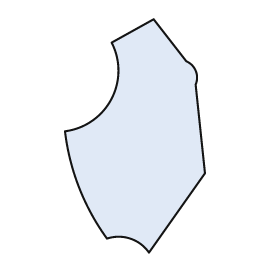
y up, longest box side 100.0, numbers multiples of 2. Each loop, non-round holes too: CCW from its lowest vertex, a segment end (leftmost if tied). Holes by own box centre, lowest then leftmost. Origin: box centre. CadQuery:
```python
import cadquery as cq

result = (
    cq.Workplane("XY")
    .moveTo(6.0, -50.0)
    .lineTo(30.0, -16.0)
    .lineTo(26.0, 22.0)
    .threePointArc((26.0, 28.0), (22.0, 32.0))
    .lineTo(8.0, 50.0)
    .lineTo(-10.0, 40.0)
    .threePointArc((-10.0, 16.0), (-30.0, 2.0))
    .threePointArc((-24.0, -22.0), (-12.0, -44.0))
    .threePointArc((-2.0, -44.0), (6.0, -50.0))
    .close()
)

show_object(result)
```